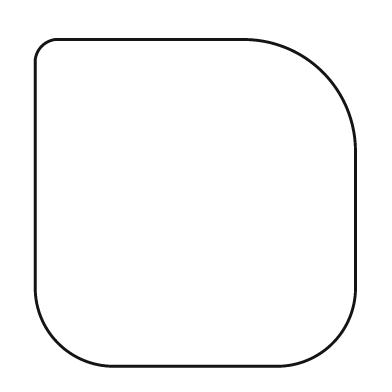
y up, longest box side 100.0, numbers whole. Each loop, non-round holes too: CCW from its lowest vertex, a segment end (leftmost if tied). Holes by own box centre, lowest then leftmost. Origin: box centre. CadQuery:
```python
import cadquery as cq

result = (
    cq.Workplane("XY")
    .moveTo(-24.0, -50.0)
    .lineTo(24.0, -50.0)
    .threePointArc((42.0, -43.0), (49.0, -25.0))
    .lineTo(49.0, 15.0)
    .threePointArc((39.0, 40.0), (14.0, 50.0))
    .lineTo(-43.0, 50.0)
    .threePointArc((-47.0, 48.0), (-49.0, 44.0))
    .lineTo(-49.0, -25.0)
    .threePointArc((-42.0, -43.0), (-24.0, -50.0))
    .close()
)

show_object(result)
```